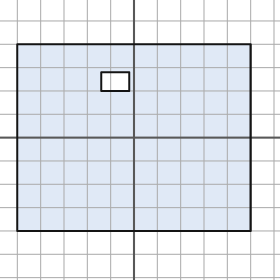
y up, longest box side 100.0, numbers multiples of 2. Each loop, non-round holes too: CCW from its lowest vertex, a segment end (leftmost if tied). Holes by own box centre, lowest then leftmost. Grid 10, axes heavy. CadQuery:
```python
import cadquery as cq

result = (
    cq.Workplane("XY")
    .moveTo(-50.0, -40.0)
    .lineTo(50.0, -40.0)
    .lineTo(50.0, 40.0)
    .lineTo(-50.0, 40.0)
    .close()
    .moveTo(-14.0, 20.0)
    .lineTo(-2.0, 20.0)
    .lineTo(-2.0, 28.0)
    .lineTo(-14.0, 28.0)
    .close()
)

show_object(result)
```